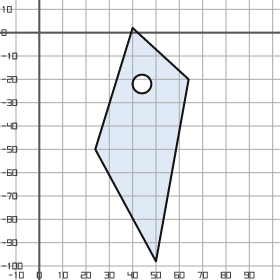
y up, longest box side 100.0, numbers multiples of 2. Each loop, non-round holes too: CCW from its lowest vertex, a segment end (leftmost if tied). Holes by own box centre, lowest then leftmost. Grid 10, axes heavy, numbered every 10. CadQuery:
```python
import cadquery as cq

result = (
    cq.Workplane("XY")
    .moveTo(50.0, -98.0)
    .lineTo(64.0, -20.0)
    .lineTo(40.0, 2.0)
    .lineTo(24.0, -50.0)
    .close()
    .moveTo(44.0, -22.0)
    .circle(4.0)
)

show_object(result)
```